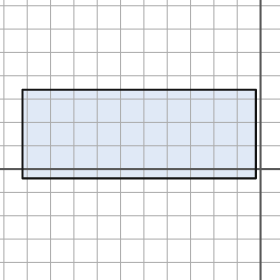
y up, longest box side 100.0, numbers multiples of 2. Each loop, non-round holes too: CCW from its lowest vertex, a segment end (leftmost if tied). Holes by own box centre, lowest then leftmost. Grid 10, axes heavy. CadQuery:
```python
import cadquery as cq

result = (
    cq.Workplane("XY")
    .moveTo(-102.0, -4.0)
    .lineTo(-2.0, -4.0)
    .lineTo(-2.0, 34.0)
    .lineTo(-102.0, 34.0)
    .close()
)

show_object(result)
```